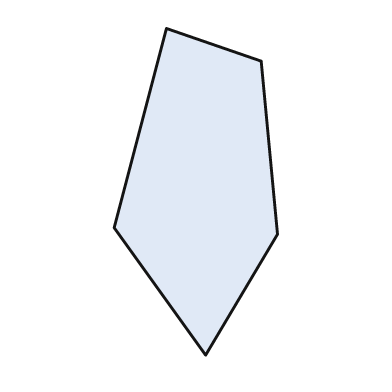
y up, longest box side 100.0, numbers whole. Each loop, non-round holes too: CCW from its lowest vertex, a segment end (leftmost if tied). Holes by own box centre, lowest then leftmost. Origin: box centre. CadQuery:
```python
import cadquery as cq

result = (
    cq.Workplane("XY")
    .moveTo(3.0, -50.0)
    .lineTo(25.0, -13.0)
    .lineTo(20.0, 40.0)
    .lineTo(-9.0, 50.0)
    .lineTo(-25.0, -11.0)
    .close()
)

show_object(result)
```